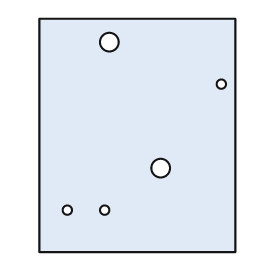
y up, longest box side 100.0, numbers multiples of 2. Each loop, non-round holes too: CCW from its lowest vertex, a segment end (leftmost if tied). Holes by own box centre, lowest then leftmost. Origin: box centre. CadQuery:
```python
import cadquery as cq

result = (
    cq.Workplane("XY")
    .moveTo(-42.0, -50.0)
    .lineTo(42.0, -50.0)
    .lineTo(42.0, 50.0)
    .lineTo(-42.0, 50.0)
    .close()
    .moveTo(-30.0, -32.0)
    .circle(2.0)
    .moveTo(-14.0, -32.0)
    .circle(2.0)
    .moveTo(10.0, -14.0)
    .circle(4.0)
    .moveTo(36.0, 22.0)
    .circle(2.0)
    .moveTo(-12.0, 40.0)
    .circle(4.0)
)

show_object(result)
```